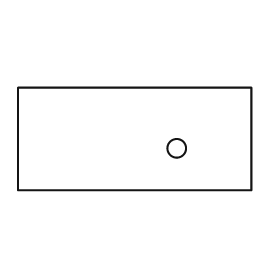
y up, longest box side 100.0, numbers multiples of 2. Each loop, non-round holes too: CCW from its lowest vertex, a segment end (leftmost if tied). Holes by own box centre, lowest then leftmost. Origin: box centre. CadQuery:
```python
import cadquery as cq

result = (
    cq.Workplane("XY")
    .moveTo(-50.0, -22.0)
    .lineTo(50.0, -22.0)
    .lineTo(50.0, 22.0)
    .lineTo(-50.0, 22.0)
    .close()
    .moveTo(18.0, -4.0)
    .circle(4.0)
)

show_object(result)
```